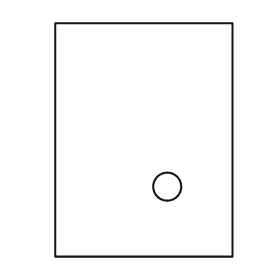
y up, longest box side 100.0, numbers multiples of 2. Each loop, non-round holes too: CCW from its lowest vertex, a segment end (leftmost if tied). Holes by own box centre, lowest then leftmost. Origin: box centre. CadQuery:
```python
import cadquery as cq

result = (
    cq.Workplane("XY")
    .moveTo(-38.0, -50.0)
    .lineTo(38.0, -50.0)
    .lineTo(38.0, 50.0)
    .lineTo(-38.0, 50.0)
    .close()
    .moveTo(10.0, -20.0)
    .circle(6.0)
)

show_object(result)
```